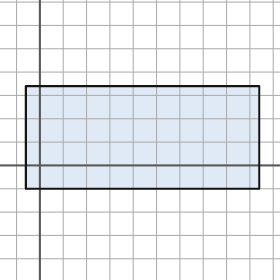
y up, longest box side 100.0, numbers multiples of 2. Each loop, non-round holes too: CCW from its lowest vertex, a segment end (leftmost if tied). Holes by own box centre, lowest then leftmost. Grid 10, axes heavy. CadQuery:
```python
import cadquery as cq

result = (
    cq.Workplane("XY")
    .moveTo(-6.0, -10.0)
    .lineTo(94.0, -10.0)
    .lineTo(94.0, 34.0)
    .lineTo(-6.0, 34.0)
    .close()
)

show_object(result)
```